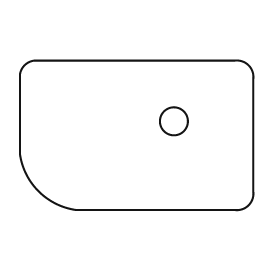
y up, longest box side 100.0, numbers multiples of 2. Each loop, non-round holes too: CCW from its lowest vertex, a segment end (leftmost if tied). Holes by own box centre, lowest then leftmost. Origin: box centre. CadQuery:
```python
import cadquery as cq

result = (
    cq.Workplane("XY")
    .moveTo(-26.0, -32.0)
    .lineTo(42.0, -32.0)
    .threePointArc((48.0, -30.0), (50.0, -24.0))
    .lineTo(50.0, 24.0)
    .threePointArc((48.0, 30.0), (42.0, 32.0))
    .lineTo(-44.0, 32.0)
    .threePointArc((-48.0, 30.0), (-50.0, 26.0))
    .lineTo(-50.0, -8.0)
    .threePointArc((-42.0, -24.0), (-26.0, -32.0))
    .close()
    .moveTo(16.0, 6.0)
    .circle(6.0)
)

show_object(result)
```